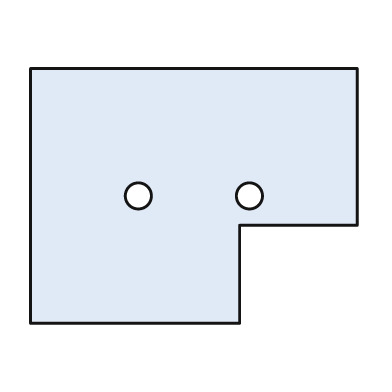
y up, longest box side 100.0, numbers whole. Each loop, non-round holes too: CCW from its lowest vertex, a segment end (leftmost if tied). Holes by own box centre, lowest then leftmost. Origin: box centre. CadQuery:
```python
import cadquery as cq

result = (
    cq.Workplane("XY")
    .moveTo(-50.0, -39.0)
    .lineTo(14.0, -39.0)
    .lineTo(14.0, -9.0)
    .lineTo(50.0, -9.0)
    .lineTo(50.0, 39.0)
    .lineTo(-50.0, 39.0)
    .close()
    .moveTo(-17.0, 0.0)
    .circle(4.0)
    .moveTo(17.0, 0.0)
    .circle(4.0)
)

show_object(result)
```